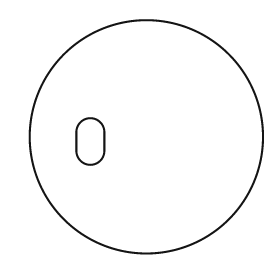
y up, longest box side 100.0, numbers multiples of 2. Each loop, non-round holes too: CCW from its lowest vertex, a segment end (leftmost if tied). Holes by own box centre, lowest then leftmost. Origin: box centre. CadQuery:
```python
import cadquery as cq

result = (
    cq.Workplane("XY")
    .moveTo(0.0, 0.0)
    .circle(50.0)
    .moveTo(-30.0, -6.0)
    .threePointArc((-24.0, -12.0), (-18.0, -6.0))
    .lineTo(-18.0, 2.0)
    .threePointArc((-24.0, 8.0), (-30.0, 2.0))
    .close()
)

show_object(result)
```